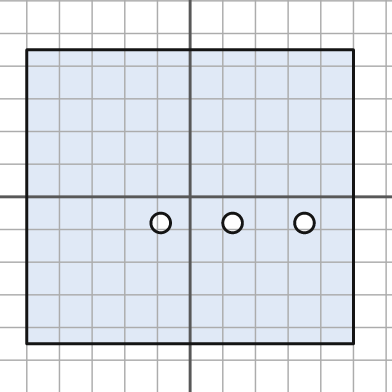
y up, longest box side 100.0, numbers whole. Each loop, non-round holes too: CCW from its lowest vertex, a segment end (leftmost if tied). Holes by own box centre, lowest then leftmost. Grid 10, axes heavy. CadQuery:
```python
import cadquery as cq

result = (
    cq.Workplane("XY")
    .moveTo(-50.0, -45.0)
    .lineTo(50.0, -45.0)
    .lineTo(50.0, 45.0)
    .lineTo(-50.0, 45.0)
    .close()
    .moveTo(-9.0, -8.0)
    .circle(3.0)
    .moveTo(13.0, -8.0)
    .circle(3.0)
    .moveTo(35.0, -8.0)
    .circle(3.0)
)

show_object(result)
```